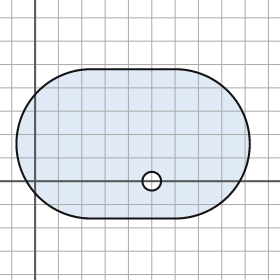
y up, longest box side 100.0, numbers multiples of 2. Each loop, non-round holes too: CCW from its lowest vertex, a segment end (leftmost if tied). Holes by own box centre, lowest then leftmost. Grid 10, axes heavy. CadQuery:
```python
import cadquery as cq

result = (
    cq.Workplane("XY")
    .moveTo(24.0, -16.0)
    .lineTo(60.0, -16.0)
    .threePointArc((92.0, 16.0), (60.0, 48.0))
    .lineTo(24.0, 48.0)
    .threePointArc((-8.0, 16.0), (24.0, -16.0))
    .close()
    .moveTo(50.0, 0.0)
    .circle(4.0)
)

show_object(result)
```